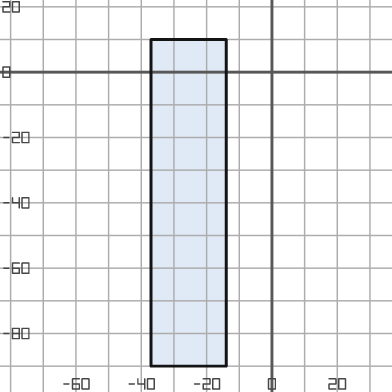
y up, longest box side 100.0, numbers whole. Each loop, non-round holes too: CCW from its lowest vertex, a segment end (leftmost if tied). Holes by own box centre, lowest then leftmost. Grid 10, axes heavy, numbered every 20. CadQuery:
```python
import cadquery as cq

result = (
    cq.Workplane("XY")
    .moveTo(-37.0, -90.0)
    .lineTo(-14.0, -90.0)
    .lineTo(-14.0, 10.0)
    .lineTo(-37.0, 10.0)
    .close()
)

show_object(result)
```